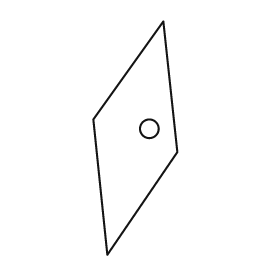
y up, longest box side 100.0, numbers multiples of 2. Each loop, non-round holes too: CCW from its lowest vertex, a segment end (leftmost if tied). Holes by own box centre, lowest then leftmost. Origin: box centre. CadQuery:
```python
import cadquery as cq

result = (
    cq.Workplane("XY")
    .moveTo(-12.0, -50.0)
    .lineTo(18.0, -6.0)
    .lineTo(12.0, 50.0)
    .lineTo(-18.0, 8.0)
    .close()
    .moveTo(6.0, 4.0)
    .circle(4.0)
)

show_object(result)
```